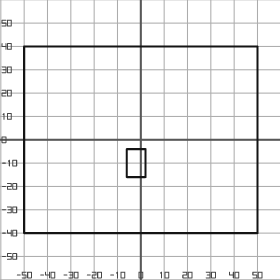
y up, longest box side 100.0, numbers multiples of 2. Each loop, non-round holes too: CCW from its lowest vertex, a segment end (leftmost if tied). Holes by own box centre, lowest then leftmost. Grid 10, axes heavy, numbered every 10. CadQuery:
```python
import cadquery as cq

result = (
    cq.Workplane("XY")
    .moveTo(-50.0, -40.0)
    .lineTo(50.0, -40.0)
    .lineTo(50.0, 40.0)
    .lineTo(-50.0, 40.0)
    .close()
    .moveTo(-6.0, -16.0)
    .lineTo(2.0, -16.0)
    .lineTo(2.0, -4.0)
    .lineTo(-6.0, -4.0)
    .close()
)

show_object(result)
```